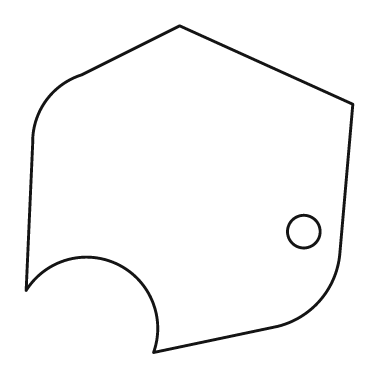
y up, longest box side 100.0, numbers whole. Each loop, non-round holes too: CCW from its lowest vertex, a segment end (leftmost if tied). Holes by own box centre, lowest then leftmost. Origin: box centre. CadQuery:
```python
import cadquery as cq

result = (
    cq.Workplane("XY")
    .moveTo(-11.0, -50.0)
    .lineTo(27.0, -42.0)
    .threePointArc((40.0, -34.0), (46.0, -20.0))
    .lineTo(50.0, 26.0)
    .lineTo(-3.0, 50.0)
    .lineTo(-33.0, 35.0)
    .threePointArc((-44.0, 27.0), (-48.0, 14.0))
    .lineTo(-50.0, -31.0)
    .threePointArc((-22.0, -23.0), (-11.0, -50.0))
    .close()
    .moveTo(35.0, -13.0)
    .circle(5.0)
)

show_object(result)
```